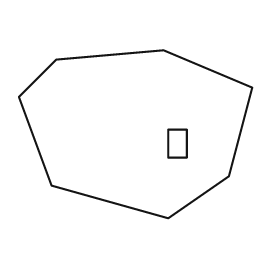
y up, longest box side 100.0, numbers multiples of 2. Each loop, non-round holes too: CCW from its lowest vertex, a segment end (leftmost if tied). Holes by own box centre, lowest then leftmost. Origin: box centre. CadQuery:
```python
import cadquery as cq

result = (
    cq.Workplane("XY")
    .moveTo(14.0, -36.0)
    .lineTo(40.0, -18.0)
    .lineTo(50.0, 20.0)
    .lineTo(12.0, 36.0)
    .lineTo(-34.0, 32.0)
    .lineTo(-50.0, 16.0)
    .lineTo(-36.0, -22.0)
    .close()
    .moveTo(14.0, -10.0)
    .lineTo(22.0, -10.0)
    .lineTo(22.0, 2.0)
    .lineTo(14.0, 2.0)
    .close()
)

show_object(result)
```